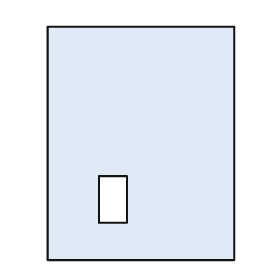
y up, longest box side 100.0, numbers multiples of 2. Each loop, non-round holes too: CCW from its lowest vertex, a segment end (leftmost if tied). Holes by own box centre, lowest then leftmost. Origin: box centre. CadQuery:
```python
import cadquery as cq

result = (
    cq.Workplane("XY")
    .moveTo(-40.0, -50.0)
    .lineTo(40.0, -50.0)
    .lineTo(40.0, 50.0)
    .lineTo(-40.0, 50.0)
    .close()
    .moveTo(-18.0, -34.0)
    .lineTo(-6.0, -34.0)
    .lineTo(-6.0, -14.0)
    .lineTo(-18.0, -14.0)
    .close()
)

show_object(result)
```